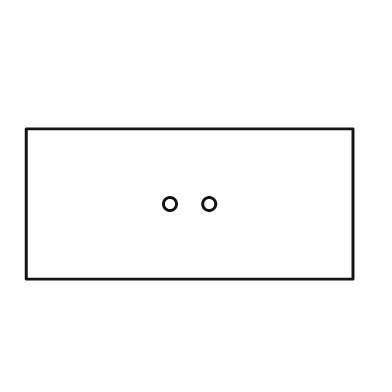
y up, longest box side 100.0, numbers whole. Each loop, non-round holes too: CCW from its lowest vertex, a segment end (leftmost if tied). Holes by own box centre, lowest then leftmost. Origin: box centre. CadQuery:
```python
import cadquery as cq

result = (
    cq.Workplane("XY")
    .moveTo(-50.0, -23.0)
    .lineTo(50.0, -23.0)
    .lineTo(50.0, 23.0)
    .lineTo(-50.0, 23.0)
    .close()
    .moveTo(-6.0, 0.0)
    .circle(2.0)
    .moveTo(6.0, 0.0)
    .circle(2.0)
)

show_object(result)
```